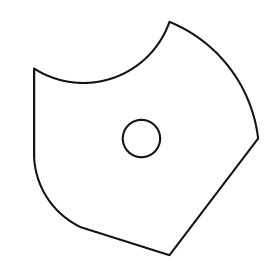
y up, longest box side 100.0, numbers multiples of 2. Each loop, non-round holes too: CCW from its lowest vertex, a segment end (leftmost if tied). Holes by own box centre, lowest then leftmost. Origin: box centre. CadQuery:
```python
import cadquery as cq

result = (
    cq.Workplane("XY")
    .moveTo(10.0, -50.0)
    .lineTo(48.0, 0.0)
    .threePointArc((36.0, 30.0), (10.0, 50.0))
    .threePointArc((-14.0, 26.0), (-48.0, 30.0))
    .lineTo(-48.0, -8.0)
    .threePointArc((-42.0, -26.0), (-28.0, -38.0))
    .close()
    .moveTo(-2.0, 0.0)
    .circle(8.0)
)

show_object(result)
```